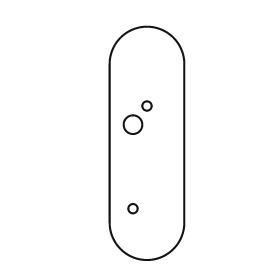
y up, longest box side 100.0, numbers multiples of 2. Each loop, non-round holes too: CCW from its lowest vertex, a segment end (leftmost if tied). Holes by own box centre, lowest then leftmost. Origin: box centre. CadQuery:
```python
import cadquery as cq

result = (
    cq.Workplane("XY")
    .moveTo(-16.0, -34.0)
    .threePointArc((0.0, -50.0), (16.0, -34.0))
    .lineTo(16.0, 34.0)
    .threePointArc((0.0, 50.0), (-16.0, 34.0))
    .close()
    .moveTo(-6.0, -28.0)
    .circle(2.0)
    .moveTo(-6.0, 8.0)
    .circle(4.0)
    .moveTo(0.0, 16.0)
    .circle(2.0)
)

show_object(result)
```